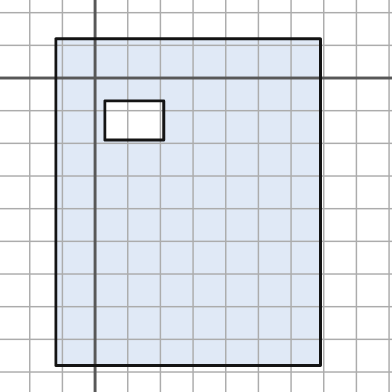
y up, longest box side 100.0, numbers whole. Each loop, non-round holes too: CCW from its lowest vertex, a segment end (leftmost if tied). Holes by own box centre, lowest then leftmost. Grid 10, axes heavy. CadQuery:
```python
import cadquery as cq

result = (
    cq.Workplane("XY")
    .moveTo(-12.0, -88.0)
    .lineTo(69.0, -88.0)
    .lineTo(69.0, 12.0)
    .lineTo(-12.0, 12.0)
    .close()
    .moveTo(3.0, -19.0)
    .lineTo(21.0, -19.0)
    .lineTo(21.0, -7.0)
    .lineTo(3.0, -7.0)
    .close()
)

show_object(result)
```